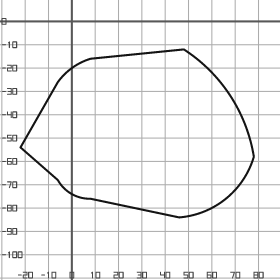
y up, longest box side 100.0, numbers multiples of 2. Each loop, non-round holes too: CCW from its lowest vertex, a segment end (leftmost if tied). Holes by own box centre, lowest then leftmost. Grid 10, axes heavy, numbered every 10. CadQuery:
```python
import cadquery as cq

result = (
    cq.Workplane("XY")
    .moveTo(46.0, -84.0)
    .threePointArc((66.0, -76.0), (78.0, -58.0))
    .threePointArc((68.0, -32.0), (48.0, -12.0))
    .lineTo(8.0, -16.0)
    .threePointArc((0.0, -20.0), (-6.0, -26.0))
    .lineTo(-22.0, -54.0)
    .lineTo(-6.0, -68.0)
    .threePointArc((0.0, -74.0), (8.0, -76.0))
    .close()
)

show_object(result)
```